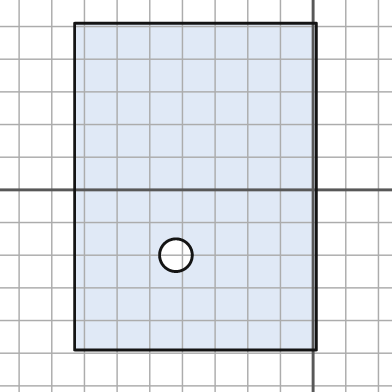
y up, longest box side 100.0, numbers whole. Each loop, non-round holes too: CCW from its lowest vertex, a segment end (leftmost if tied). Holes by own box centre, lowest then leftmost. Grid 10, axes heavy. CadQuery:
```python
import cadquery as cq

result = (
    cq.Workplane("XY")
    .moveTo(-73.0, -49.0)
    .lineTo(1.0, -49.0)
    .lineTo(1.0, 51.0)
    .lineTo(-73.0, 51.0)
    .close()
    .moveTo(-42.0, -20.0)
    .circle(5.0)
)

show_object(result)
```